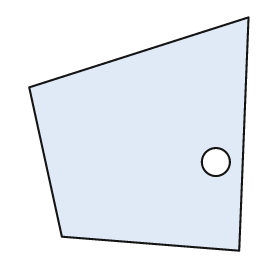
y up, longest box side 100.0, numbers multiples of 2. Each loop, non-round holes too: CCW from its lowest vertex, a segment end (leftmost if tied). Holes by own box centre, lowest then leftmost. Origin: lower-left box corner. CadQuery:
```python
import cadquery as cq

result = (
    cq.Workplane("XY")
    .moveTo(90.0, 0.0)
    .lineTo(94.0, 100.0)
    .lineTo(0.0, 70.0)
    .lineTo(14.0, 6.0)
    .close()
    .moveTo(80.0, 38.0)
    .circle(6.0)
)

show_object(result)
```